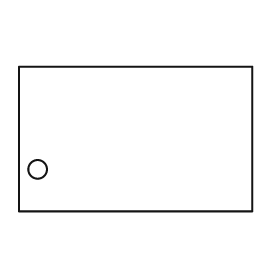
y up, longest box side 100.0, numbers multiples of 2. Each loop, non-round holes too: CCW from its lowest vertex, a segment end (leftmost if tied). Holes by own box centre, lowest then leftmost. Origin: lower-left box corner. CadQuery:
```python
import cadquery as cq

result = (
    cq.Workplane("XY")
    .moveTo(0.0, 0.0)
    .lineTo(100.0, 0.0)
    .lineTo(100.0, 62.0)
    .lineTo(0.0, 62.0)
    .close()
    .moveTo(8.0, 18.0)
    .circle(4.0)
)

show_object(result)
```